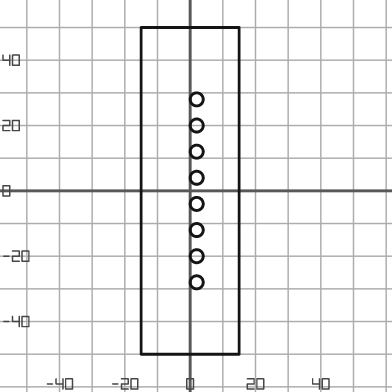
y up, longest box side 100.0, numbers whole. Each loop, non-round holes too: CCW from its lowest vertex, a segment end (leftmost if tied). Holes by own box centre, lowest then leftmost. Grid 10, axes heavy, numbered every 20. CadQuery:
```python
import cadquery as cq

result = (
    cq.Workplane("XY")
    .moveTo(-15.0, -50.0)
    .lineTo(15.0, -50.0)
    .lineTo(15.0, 50.0)
    .lineTo(-15.0, 50.0)
    .close()
    .moveTo(2.0, -28.0)
    .circle(2.0)
    .moveTo(2.0, -20.0)
    .circle(2.0)
    .moveTo(2.0, -12.0)
    .circle(2.0)
    .moveTo(2.0, -4.0)
    .circle(2.0)
    .moveTo(2.0, 4.0)
    .circle(2.0)
    .moveTo(2.0, 12.0)
    .circle(2.0)
    .moveTo(2.0, 20.0)
    .circle(2.0)
    .moveTo(2.0, 28.0)
    .circle(2.0)
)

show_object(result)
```